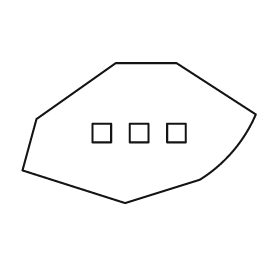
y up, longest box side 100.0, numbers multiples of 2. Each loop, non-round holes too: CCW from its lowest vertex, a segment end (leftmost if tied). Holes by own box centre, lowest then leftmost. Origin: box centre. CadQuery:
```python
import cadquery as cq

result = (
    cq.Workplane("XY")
    .moveTo(-6.0, -30.0)
    .lineTo(26.0, -20.0)
    .threePointArc((40.0, -8.0), (50.0, 8.0))
    .lineTo(16.0, 30.0)
    .lineTo(-10.0, 30.0)
    .lineTo(-44.0, 6.0)
    .lineTo(-50.0, -16.0)
    .close()
    .moveTo(-20.0, -4.0)
    .lineTo(-12.0, -4.0)
    .lineTo(-12.0, 4.0)
    .lineTo(-20.0, 4.0)
    .close()
    .moveTo(-4.0, -4.0)
    .lineTo(4.0, -4.0)
    .lineTo(4.0, 4.0)
    .lineTo(-4.0, 4.0)
    .close()
    .moveTo(12.0, -4.0)
    .lineTo(20.0, -4.0)
    .lineTo(20.0, 4.0)
    .lineTo(12.0, 4.0)
    .close()
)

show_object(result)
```